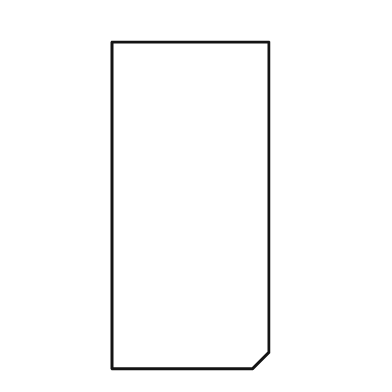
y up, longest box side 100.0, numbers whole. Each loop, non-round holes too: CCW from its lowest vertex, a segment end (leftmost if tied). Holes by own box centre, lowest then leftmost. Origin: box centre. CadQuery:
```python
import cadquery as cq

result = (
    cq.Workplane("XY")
    .moveTo(-24.0, -50.0)
    .lineTo(19.0, -50.0)
    .lineTo(24.0, -45.0)
    .lineTo(24.0, 50.0)
    .lineTo(-24.0, 50.0)
    .close()
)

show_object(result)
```